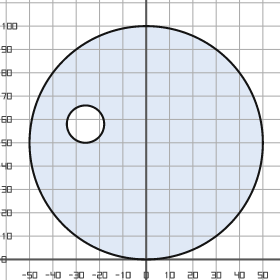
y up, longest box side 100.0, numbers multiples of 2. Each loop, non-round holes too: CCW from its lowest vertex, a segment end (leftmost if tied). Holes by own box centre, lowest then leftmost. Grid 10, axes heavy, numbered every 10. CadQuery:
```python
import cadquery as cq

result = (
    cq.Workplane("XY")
    .moveTo(0.0, 50.0)
    .circle(50.0)
    .moveTo(-26.0, 58.0)
    .circle(8.0)
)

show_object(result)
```